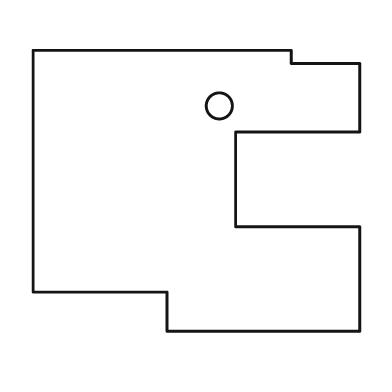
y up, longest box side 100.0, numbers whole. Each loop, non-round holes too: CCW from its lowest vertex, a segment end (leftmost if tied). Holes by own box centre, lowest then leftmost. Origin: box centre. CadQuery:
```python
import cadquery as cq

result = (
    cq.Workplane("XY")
    .moveTo(-9.0, -43.0)
    .lineTo(50.0, -43.0)
    .lineTo(50.0, -11.0)
    .lineTo(12.0, -11.0)
    .lineTo(12.0, 18.0)
    .lineTo(50.0, 18.0)
    .lineTo(50.0, 39.0)
    .lineTo(29.0, 39.0)
    .lineTo(29.0, 43.0)
    .lineTo(-50.0, 43.0)
    .lineTo(-50.0, -31.0)
    .lineTo(-9.0, -31.0)
    .close()
    .moveTo(7.0, 26.0)
    .circle(4.0)
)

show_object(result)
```